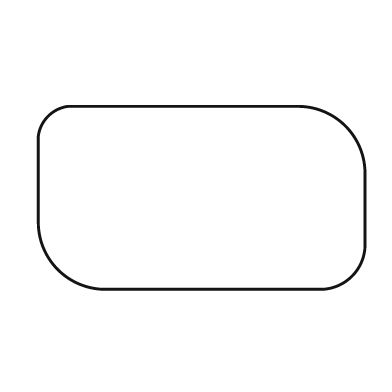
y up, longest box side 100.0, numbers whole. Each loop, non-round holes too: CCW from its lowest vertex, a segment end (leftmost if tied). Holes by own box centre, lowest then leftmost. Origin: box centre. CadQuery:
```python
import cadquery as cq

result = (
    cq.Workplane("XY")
    .moveTo(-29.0, -28.0)
    .lineTo(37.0, -28.0)
    .threePointArc((46.0, -24.0), (50.0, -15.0))
    .lineTo(50.0, 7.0)
    .threePointArc((44.0, 22.0), (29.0, 28.0))
    .lineTo(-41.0, 28.0)
    .threePointArc((-47.0, 25.0), (-50.0, 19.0))
    .lineTo(-50.0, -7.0)
    .threePointArc((-44.0, -22.0), (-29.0, -28.0))
    .close()
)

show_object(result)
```